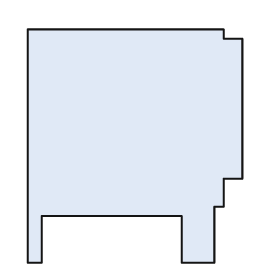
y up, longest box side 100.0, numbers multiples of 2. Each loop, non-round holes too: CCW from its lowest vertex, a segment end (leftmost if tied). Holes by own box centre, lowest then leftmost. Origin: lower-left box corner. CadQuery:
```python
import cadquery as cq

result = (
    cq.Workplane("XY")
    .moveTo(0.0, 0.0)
    .lineTo(6.0, 0.0)
    .lineTo(6.0, 20.0)
    .lineTo(66.0, 20.0)
    .lineTo(66.0, 0.0)
    .lineTo(80.0, 0.0)
    .lineTo(80.0, 24.0)
    .lineTo(84.0, 24.0)
    .lineTo(84.0, 36.0)
    .lineTo(92.0, 36.0)
    .lineTo(92.0, 96.0)
    .lineTo(84.0, 96.0)
    .lineTo(84.0, 100.0)
    .lineTo(0.0, 100.0)
    .close()
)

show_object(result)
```